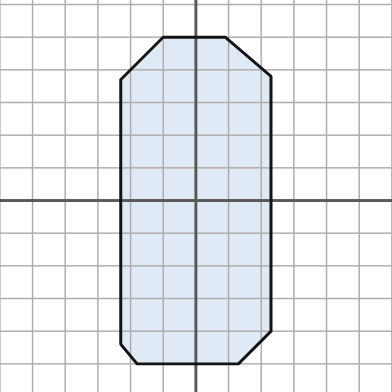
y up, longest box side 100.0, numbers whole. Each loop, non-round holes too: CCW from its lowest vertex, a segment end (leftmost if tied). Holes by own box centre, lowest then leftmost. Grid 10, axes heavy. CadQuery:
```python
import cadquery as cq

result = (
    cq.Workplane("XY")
    .moveTo(-18.0, -50.0)
    .lineTo(13.0, -50.0)
    .lineTo(23.0, -40.0)
    .lineTo(23.0, 38.0)
    .lineTo(9.0, 50.0)
    .lineTo(-10.0, 50.0)
    .lineTo(-23.0, 37.0)
    .lineTo(-23.0, -44.0)
    .close()
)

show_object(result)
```